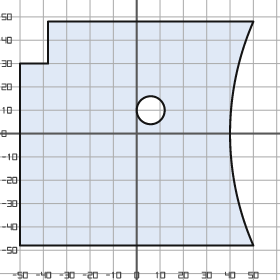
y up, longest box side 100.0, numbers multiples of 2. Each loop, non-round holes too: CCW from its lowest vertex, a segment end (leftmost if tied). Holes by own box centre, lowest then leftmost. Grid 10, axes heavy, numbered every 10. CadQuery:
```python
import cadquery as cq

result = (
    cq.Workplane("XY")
    .moveTo(-50.0, -48.0)
    .lineTo(50.0, -48.0)
    .threePointArc((40.0, 0.0), (50.0, 48.0))
    .lineTo(-38.0, 48.0)
    .lineTo(-38.0, 30.0)
    .lineTo(-50.0, 30.0)
    .close()
    .moveTo(6.0, 10.0)
    .circle(6.0)
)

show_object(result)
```